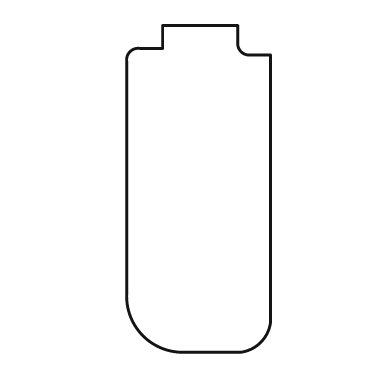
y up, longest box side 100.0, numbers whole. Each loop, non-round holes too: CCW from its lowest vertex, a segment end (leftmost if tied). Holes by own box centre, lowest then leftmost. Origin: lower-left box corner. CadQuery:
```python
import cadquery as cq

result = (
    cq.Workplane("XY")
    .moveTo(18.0, 0.0)
    .lineTo(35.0, 0.0)
    .threePointArc((41.0, 3.0), (44.0, 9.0))
    .lineTo(44.0, 91.0)
    .lineTo(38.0, 91.0)
    .threePointArc((35.0, 92.0), (34.0, 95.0))
    .lineTo(34.0, 100.0)
    .lineTo(11.0, 100.0)
    .lineTo(11.0, 93.0)
    .lineTo(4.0, 93.0)
    .threePointArc((1.0, 92.0), (0.0, 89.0))
    .lineTo(0.0, 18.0)
    .threePointArc((5.0, 5.0), (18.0, 0.0))
    .close()
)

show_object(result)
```